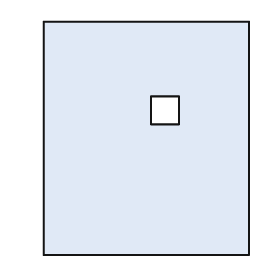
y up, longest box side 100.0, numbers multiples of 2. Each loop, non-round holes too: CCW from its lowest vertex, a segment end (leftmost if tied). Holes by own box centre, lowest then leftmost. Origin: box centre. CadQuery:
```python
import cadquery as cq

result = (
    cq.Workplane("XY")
    .moveTo(-44.0, -50.0)
    .lineTo(44.0, -50.0)
    .lineTo(44.0, 50.0)
    .lineTo(-44.0, 50.0)
    .close()
    .moveTo(2.0, 6.0)
    .lineTo(14.0, 6.0)
    .lineTo(14.0, 18.0)
    .lineTo(2.0, 18.0)
    .close()
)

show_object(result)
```